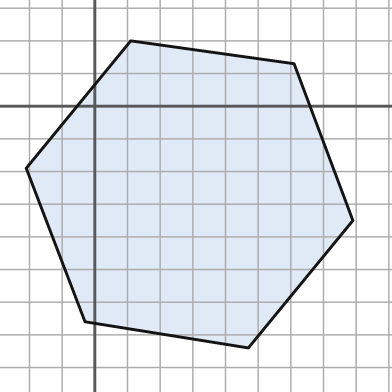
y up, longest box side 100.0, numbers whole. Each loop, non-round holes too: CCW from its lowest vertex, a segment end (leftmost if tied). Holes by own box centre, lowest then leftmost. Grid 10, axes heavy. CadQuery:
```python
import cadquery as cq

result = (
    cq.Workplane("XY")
    .moveTo(47.0, -74.0)
    .lineTo(79.0, -35.0)
    .lineTo(61.0, 13.0)
    .lineTo(11.0, 20.0)
    .lineTo(-21.0, -19.0)
    .lineTo(-3.0, -66.0)
    .close()
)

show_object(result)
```